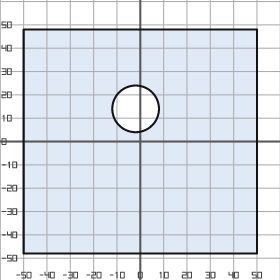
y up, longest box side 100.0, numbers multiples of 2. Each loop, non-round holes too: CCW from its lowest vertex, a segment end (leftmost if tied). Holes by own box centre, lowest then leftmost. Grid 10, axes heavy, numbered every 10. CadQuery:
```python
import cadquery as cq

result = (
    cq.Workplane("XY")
    .moveTo(-50.0, -48.0)
    .lineTo(50.0, -48.0)
    .lineTo(50.0, 48.0)
    .lineTo(-50.0, 48.0)
    .close()
    .moveTo(-2.0, 14.0)
    .circle(10.0)
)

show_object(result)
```